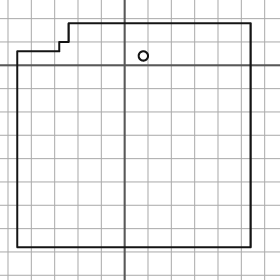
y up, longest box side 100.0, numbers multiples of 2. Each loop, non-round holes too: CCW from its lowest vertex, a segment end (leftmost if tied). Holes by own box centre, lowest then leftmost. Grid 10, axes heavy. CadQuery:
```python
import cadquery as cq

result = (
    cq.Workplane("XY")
    .moveTo(-46.0, -78.0)
    .lineTo(54.0, -78.0)
    .lineTo(54.0, 18.0)
    .lineTo(-24.0, 18.0)
    .lineTo(-24.0, 10.0)
    .lineTo(-28.0, 10.0)
    .lineTo(-28.0, 6.0)
    .lineTo(-46.0, 6.0)
    .close()
    .moveTo(8.0, 4.0)
    .circle(2.0)
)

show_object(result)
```